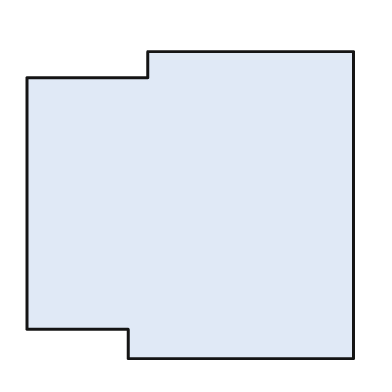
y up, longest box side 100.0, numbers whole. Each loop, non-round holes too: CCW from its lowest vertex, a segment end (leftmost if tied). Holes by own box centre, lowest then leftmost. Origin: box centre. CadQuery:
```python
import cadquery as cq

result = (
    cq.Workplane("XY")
    .moveTo(-19.0, -47.0)
    .lineTo(50.0, -47.0)
    .lineTo(50.0, 47.0)
    .lineTo(-13.0, 47.0)
    .lineTo(-13.0, 39.0)
    .lineTo(-50.0, 39.0)
    .lineTo(-50.0, -38.0)
    .lineTo(-19.0, -38.0)
    .close()
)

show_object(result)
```